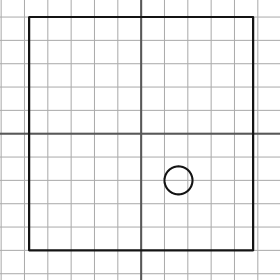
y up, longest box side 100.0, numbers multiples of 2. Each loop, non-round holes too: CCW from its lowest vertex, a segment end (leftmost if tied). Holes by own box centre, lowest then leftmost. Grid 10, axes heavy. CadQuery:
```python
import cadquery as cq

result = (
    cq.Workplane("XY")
    .moveTo(-48.0, -50.0)
    .lineTo(48.0, -50.0)
    .lineTo(48.0, 50.0)
    .lineTo(-48.0, 50.0)
    .close()
    .moveTo(16.0, -20.0)
    .circle(6.0)
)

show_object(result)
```